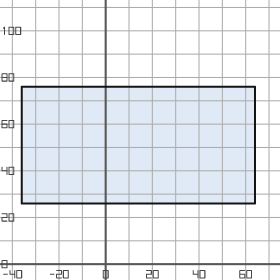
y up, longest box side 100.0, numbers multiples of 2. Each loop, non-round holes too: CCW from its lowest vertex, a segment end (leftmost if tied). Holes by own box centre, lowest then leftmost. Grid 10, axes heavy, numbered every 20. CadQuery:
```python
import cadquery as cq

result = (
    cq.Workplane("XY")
    .moveTo(-36.0, 26.0)
    .lineTo(64.0, 26.0)
    .lineTo(64.0, 76.0)
    .lineTo(-36.0, 76.0)
    .close()
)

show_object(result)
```